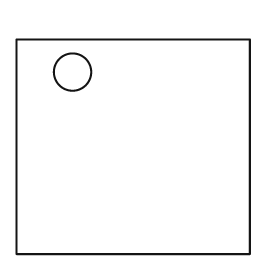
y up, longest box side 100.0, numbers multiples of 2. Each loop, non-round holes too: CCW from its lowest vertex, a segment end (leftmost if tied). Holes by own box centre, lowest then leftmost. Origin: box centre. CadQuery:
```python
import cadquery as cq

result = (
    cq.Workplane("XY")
    .moveTo(-50.0, -46.0)
    .lineTo(50.0, -46.0)
    .lineTo(50.0, 46.0)
    .lineTo(-50.0, 46.0)
    .close()
    .moveTo(-26.0, 32.0)
    .circle(8.0)
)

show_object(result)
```